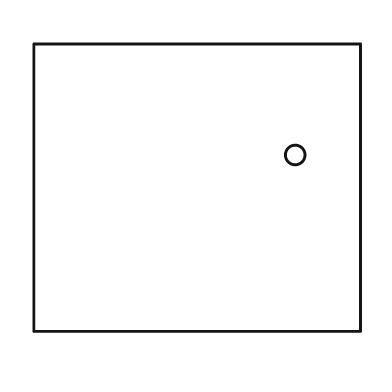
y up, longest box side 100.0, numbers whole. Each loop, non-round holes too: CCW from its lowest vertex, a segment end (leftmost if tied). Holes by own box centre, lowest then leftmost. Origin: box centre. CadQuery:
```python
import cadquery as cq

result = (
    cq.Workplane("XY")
    .moveTo(-50.0, -44.0)
    .lineTo(50.0, -44.0)
    .lineTo(50.0, 44.0)
    .lineTo(-50.0, 44.0)
    .close()
    .moveTo(30.0, 10.0)
    .circle(3.0)
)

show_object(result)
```